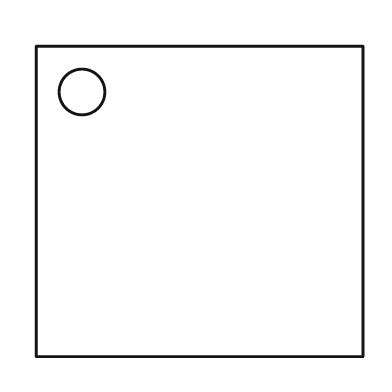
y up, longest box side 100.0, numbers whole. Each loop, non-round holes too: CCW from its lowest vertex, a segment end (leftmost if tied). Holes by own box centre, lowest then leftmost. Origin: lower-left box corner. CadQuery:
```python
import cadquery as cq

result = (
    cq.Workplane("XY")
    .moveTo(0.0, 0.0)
    .lineTo(100.0, 0.0)
    .lineTo(100.0, 95.0)
    .lineTo(0.0, 95.0)
    .close()
    .moveTo(14.0, 81.0)
    .circle(7.0)
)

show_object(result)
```